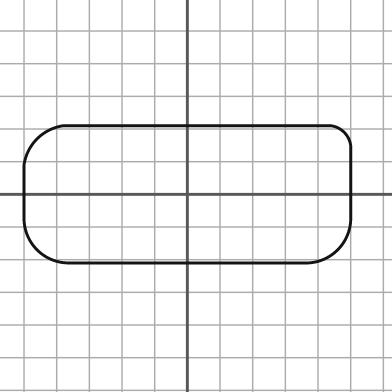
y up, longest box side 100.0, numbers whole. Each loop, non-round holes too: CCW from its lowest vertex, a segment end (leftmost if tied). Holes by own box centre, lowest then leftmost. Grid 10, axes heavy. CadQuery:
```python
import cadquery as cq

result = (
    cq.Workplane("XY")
    .moveTo(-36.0, -21.0)
    .lineTo(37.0, -21.0)
    .threePointArc((46.0, -17.0), (50.0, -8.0))
    .lineTo(50.0, 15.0)
    .threePointArc((48.0, 19.0), (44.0, 21.0))
    .lineTo(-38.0, 21.0)
    .threePointArc((-46.0, 17.0), (-50.0, 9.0))
    .lineTo(-50.0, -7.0)
    .threePointArc((-46.0, -17.0), (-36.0, -21.0))
    .close()
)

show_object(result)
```